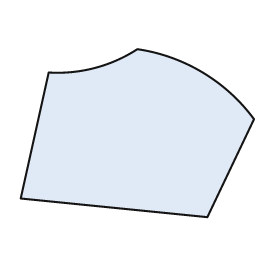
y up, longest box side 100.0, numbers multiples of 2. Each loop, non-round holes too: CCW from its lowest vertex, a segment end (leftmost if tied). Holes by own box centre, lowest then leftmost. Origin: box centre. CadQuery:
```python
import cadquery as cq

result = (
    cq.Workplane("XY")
    .moveTo(30.0, -36.0)
    .lineTo(50.0, 6.0)
    .threePointArc((28.0, 26.0), (0.0, 36.0))
    .threePointArc((-18.0, 28.0), (-38.0, 26.0))
    .lineTo(-50.0, -28.0)
    .close()
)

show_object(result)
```